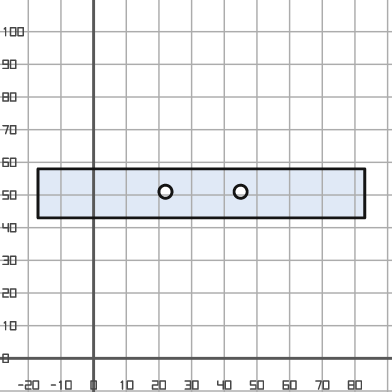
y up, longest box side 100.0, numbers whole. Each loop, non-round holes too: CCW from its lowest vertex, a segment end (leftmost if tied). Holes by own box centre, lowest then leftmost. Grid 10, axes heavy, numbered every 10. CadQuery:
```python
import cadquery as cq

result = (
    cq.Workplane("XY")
    .moveTo(-17.0, 43.0)
    .lineTo(83.0, 43.0)
    .lineTo(83.0, 58.0)
    .lineTo(-17.0, 58.0)
    .close()
    .moveTo(22.0, 51.0)
    .circle(2.0)
    .moveTo(45.0, 51.0)
    .circle(2.0)
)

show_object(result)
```